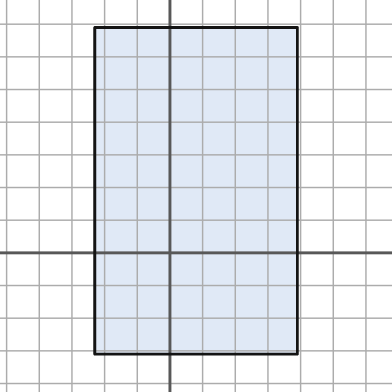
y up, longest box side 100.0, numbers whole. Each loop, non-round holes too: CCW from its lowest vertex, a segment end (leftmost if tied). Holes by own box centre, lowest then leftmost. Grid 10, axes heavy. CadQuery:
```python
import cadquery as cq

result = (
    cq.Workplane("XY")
    .moveTo(-23.0, -31.0)
    .lineTo(39.0, -31.0)
    .lineTo(39.0, 69.0)
    .lineTo(-23.0, 69.0)
    .close()
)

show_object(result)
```